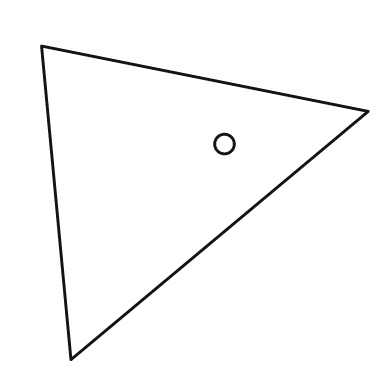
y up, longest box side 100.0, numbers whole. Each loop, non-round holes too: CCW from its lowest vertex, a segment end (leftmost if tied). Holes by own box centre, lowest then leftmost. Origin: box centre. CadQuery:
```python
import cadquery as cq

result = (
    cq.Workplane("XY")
    .moveTo(-41.0, -48.0)
    .lineTo(50.0, 28.0)
    .lineTo(-50.0, 48.0)
    .close()
    .moveTo(6.0, 18.0)
    .circle(3.0)
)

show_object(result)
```